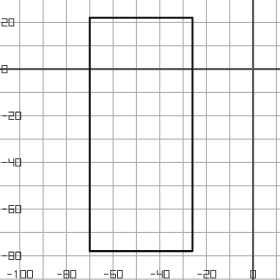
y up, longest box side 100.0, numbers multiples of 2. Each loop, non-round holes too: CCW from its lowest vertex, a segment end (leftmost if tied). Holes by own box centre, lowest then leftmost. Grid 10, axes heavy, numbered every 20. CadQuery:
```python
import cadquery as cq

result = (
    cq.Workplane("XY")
    .moveTo(-70.0, -78.0)
    .lineTo(-26.0, -78.0)
    .lineTo(-26.0, 22.0)
    .lineTo(-70.0, 22.0)
    .close()
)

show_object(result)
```